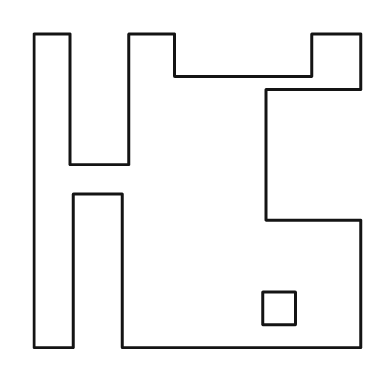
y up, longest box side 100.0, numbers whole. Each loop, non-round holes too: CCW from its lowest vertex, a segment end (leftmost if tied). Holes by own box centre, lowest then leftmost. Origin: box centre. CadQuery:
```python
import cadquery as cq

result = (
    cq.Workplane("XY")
    .moveTo(-50.0, -48.0)
    .lineTo(-38.0, -48.0)
    .lineTo(-38.0, -1.0)
    .lineTo(-23.0, -1.0)
    .lineTo(-23.0, -48.0)
    .lineTo(50.0, -48.0)
    .lineTo(50.0, -9.0)
    .lineTo(21.0, -9.0)
    .lineTo(21.0, 31.0)
    .lineTo(50.0, 31.0)
    .lineTo(50.0, 48.0)
    .lineTo(35.0, 48.0)
    .lineTo(35.0, 35.0)
    .lineTo(-7.0, 35.0)
    .lineTo(-7.0, 48.0)
    .lineTo(-21.0, 48.0)
    .lineTo(-21.0, 8.0)
    .lineTo(-39.0, 8.0)
    .lineTo(-39.0, 48.0)
    .lineTo(-50.0, 48.0)
    .close()
    .moveTo(20.0, -41.0)
    .lineTo(30.0, -41.0)
    .lineTo(30.0, -31.0)
    .lineTo(20.0, -31.0)
    .close()
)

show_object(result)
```